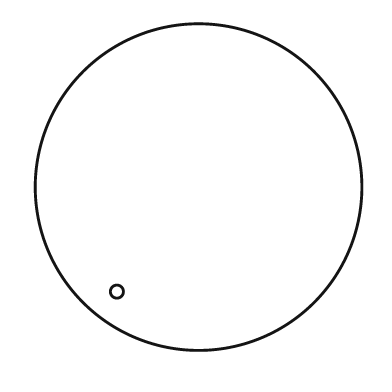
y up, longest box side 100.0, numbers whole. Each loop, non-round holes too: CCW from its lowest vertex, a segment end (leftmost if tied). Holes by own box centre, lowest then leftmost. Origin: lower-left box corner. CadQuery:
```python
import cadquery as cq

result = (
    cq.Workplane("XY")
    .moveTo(50.0, 50.0)
    .circle(50.0)
    .moveTo(25.0, 18.0)
    .circle(2.0)
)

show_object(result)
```